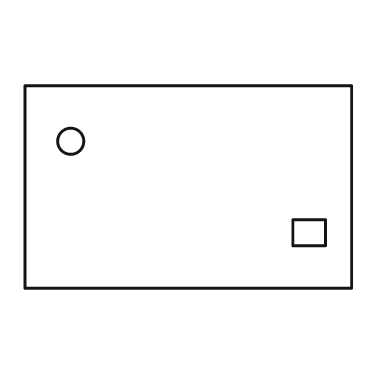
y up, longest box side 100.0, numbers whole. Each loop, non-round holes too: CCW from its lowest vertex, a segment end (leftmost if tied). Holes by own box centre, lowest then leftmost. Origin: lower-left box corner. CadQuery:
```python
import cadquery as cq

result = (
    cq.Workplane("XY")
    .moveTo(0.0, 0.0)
    .lineTo(100.0, 0.0)
    .lineTo(100.0, 62.0)
    .lineTo(0.0, 62.0)
    .close()
    .moveTo(82.0, 13.0)
    .lineTo(92.0, 13.0)
    .lineTo(92.0, 21.0)
    .lineTo(82.0, 21.0)
    .close()
    .moveTo(14.0, 45.0)
    .circle(4.0)
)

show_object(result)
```